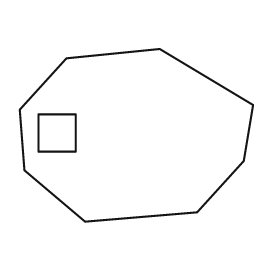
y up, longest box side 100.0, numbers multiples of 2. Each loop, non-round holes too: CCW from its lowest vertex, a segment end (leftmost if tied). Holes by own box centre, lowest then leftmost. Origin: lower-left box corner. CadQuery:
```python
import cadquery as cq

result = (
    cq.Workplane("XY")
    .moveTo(28.0, 0.0)
    .lineTo(76.0, 4.0)
    .lineTo(96.0, 26.0)
    .lineTo(100.0, 50.0)
    .lineTo(60.0, 74.0)
    .lineTo(20.0, 70.0)
    .lineTo(0.0, 48.0)
    .lineTo(2.0, 22.0)
    .close()
    .moveTo(8.0, 30.0)
    .lineTo(24.0, 30.0)
    .lineTo(24.0, 46.0)
    .lineTo(8.0, 46.0)
    .close()
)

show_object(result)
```